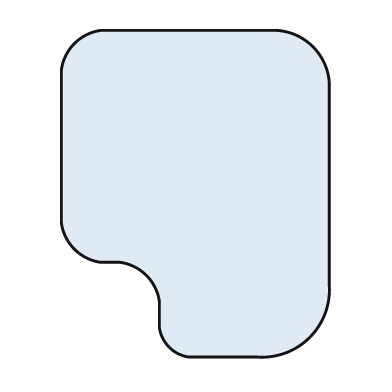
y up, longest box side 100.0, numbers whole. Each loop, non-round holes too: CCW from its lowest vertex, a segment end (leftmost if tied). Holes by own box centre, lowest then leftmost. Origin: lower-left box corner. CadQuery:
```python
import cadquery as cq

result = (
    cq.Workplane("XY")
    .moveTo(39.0, 0.0)
    .lineTo(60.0, 0.0)
    .threePointArc((76.0, 6.0), (82.0, 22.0))
    .lineTo(82.0, 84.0)
    .threePointArc((77.0, 95.0), (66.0, 100.0))
    .lineTo(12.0, 100.0)
    .threePointArc((4.0, 96.0), (0.0, 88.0))
    .lineTo(0.0, 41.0)
    .threePointArc((4.0, 33.0), (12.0, 29.0))
    .lineTo(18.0, 29.0)
    .threePointArc((26.0, 25.0), (30.0, 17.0))
    .lineTo(30.0, 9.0)
    .threePointArc((33.0, 3.0), (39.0, 0.0))
    .close()
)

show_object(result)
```